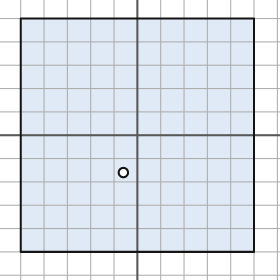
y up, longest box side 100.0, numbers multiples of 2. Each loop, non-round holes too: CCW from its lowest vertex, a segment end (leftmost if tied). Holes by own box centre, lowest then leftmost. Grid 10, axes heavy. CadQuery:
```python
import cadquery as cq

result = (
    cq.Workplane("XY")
    .moveTo(-50.0, -50.0)
    .lineTo(50.0, -50.0)
    .lineTo(50.0, 50.0)
    .lineTo(-50.0, 50.0)
    .close()
    .moveTo(-6.0, -16.0)
    .circle(2.0)
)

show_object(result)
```